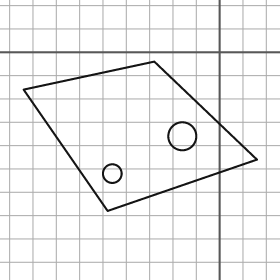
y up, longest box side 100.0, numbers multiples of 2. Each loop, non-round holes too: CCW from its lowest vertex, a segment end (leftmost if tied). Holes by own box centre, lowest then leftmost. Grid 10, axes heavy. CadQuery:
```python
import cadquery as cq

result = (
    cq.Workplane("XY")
    .moveTo(-48.0, -68.0)
    .lineTo(16.0, -46.0)
    .lineTo(-28.0, -4.0)
    .lineTo(-84.0, -16.0)
    .close()
    .moveTo(-46.0, -52.0)
    .circle(4.0)
    .moveTo(-16.0, -36.0)
    .circle(6.0)
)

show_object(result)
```